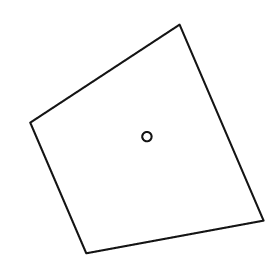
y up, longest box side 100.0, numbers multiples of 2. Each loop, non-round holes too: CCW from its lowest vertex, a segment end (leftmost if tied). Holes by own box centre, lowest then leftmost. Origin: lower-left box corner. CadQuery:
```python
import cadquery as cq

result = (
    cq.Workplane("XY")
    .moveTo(24.0, 0.0)
    .lineTo(100.0, 14.0)
    .lineTo(64.0, 98.0)
    .lineTo(0.0, 56.0)
    .close()
    .moveTo(50.0, 50.0)
    .circle(2.0)
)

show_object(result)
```